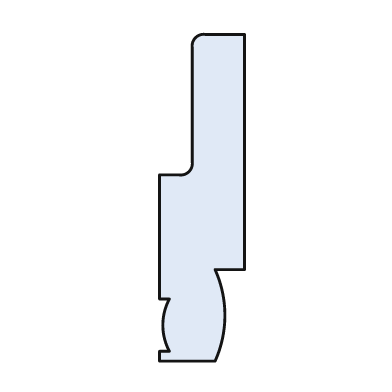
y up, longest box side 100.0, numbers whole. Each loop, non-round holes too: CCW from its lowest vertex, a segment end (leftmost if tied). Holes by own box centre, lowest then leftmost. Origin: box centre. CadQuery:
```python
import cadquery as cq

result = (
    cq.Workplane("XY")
    .moveTo(-13.0, -50.0)
    .lineTo(4.0, -50.0)
    .threePointArc((7.0, -36.0), (4.0, -22.0))
    .lineTo(13.0, -22.0)
    .lineTo(13.0, 50.0)
    .lineTo(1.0, 50.0)
    .threePointArc((-2.0, 49.0), (-3.0, 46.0))
    .lineTo(-3.0, 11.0)
    .threePointArc((-4.0, 8.0), (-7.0, 7.0))
    .lineTo(-13.0, 7.0)
    .lineTo(-13.0, -31.0)
    .lineTo(-10.0, -31.0)
    .threePointArc((-12.0, -39.0), (-10.0, -47.0))
    .lineTo(-13.0, -47.0)
    .close()
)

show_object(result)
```